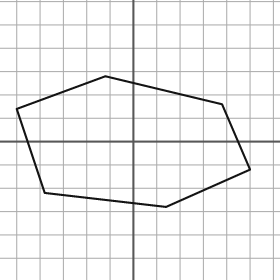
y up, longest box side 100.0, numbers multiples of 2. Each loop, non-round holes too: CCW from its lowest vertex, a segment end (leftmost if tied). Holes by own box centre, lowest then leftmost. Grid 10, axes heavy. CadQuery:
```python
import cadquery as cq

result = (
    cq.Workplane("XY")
    .moveTo(14.0, -28.0)
    .lineTo(50.0, -12.0)
    .lineTo(38.0, 16.0)
    .lineTo(-12.0, 28.0)
    .lineTo(-50.0, 14.0)
    .lineTo(-38.0, -22.0)
    .close()
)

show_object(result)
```